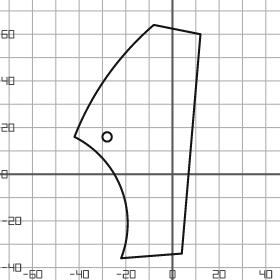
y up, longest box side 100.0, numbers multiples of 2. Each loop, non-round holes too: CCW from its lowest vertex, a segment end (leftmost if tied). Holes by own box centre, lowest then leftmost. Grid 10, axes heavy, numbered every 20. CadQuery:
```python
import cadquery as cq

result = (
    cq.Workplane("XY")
    .moveTo(-22.0, -36.0)
    .lineTo(4.0, -34.0)
    .lineTo(12.0, 60.0)
    .lineTo(-8.0, 64.0)
    .threePointArc((-28.0, 42.0), (-42.0, 16.0))
    .threePointArc((-22.0, -6.0), (-22.0, -36.0))
    .close()
    .moveTo(-28.0, 16.0)
    .circle(2.0)
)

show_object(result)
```